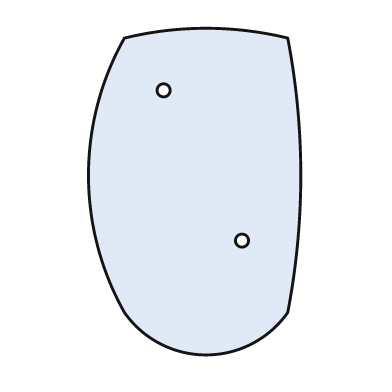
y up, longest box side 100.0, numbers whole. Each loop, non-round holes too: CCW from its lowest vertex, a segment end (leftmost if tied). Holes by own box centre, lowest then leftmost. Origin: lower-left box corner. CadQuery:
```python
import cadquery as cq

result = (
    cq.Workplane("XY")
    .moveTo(11.0, 13.0)
    .threePointArc((36.0, 0.0), (61.0, 13.0))
    .threePointArc((65.0, 55.0), (61.0, 97.0))
    .threePointArc((36.0, 100.0), (11.0, 97.0))
    .threePointArc((0.0, 55.0), (11.0, 13.0))
    .close()
    .moveTo(47.0, 35.0)
    .circle(2.0)
    .moveTo(23.0, 81.0)
    .circle(2.0)
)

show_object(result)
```